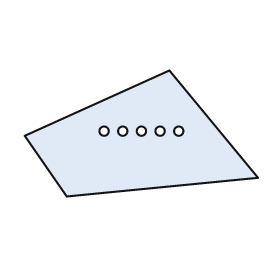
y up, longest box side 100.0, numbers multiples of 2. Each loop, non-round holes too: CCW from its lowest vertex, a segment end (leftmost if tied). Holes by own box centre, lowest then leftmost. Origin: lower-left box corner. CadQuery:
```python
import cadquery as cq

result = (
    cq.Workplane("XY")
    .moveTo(18.0, 0.0)
    .lineTo(100.0, 8.0)
    .lineTo(62.0, 54.0)
    .lineTo(0.0, 26.0)
    .close()
    .moveTo(34.0, 28.0)
    .circle(2.0)
    .moveTo(42.0, 28.0)
    .circle(2.0)
    .moveTo(50.0, 28.0)
    .circle(2.0)
    .moveTo(58.0, 28.0)
    .circle(2.0)
    .moveTo(66.0, 28.0)
    .circle(2.0)
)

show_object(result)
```